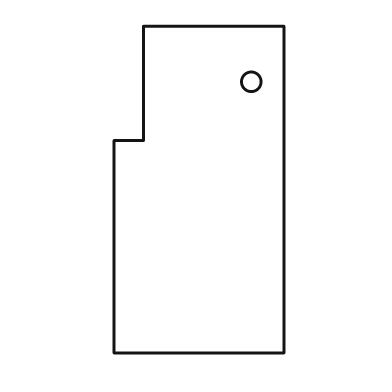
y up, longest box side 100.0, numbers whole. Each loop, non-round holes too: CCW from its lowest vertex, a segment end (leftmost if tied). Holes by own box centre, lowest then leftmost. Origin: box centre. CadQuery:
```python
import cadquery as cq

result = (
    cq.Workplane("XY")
    .moveTo(-26.0, -50.0)
    .lineTo(26.0, -50.0)
    .lineTo(26.0, 50.0)
    .lineTo(-17.0, 50.0)
    .lineTo(-17.0, 15.0)
    .lineTo(-26.0, 15.0)
    .close()
    .moveTo(16.0, 33.0)
    .circle(3.0)
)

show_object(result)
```